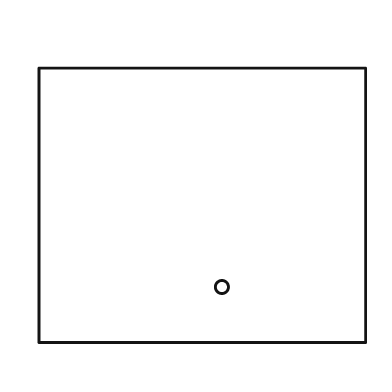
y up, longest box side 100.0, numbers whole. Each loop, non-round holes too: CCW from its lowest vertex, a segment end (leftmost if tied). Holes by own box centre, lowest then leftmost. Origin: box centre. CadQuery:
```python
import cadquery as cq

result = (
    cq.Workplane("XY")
    .moveTo(-50.0, -42.0)
    .lineTo(50.0, -42.0)
    .lineTo(50.0, 42.0)
    .lineTo(-50.0, 42.0)
    .close()
    .moveTo(6.0, -25.0)
    .circle(2.0)
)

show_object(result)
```